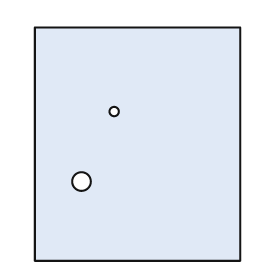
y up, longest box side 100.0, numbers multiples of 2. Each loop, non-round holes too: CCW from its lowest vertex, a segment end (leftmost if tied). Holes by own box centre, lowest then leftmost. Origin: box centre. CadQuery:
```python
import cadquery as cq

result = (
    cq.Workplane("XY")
    .moveTo(-44.0, -50.0)
    .lineTo(44.0, -50.0)
    .lineTo(44.0, 50.0)
    .lineTo(-44.0, 50.0)
    .close()
    .moveTo(-24.0, -16.0)
    .circle(4.0)
    .moveTo(-10.0, 14.0)
    .circle(2.0)
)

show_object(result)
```